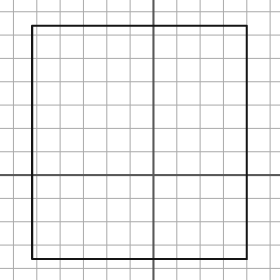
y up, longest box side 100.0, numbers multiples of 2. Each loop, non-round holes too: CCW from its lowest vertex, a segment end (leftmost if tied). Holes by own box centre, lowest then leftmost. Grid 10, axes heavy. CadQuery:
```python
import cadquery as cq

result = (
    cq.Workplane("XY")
    .moveTo(-52.0, -36.0)
    .lineTo(40.0, -36.0)
    .lineTo(40.0, 64.0)
    .lineTo(-52.0, 64.0)
    .close()
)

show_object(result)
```